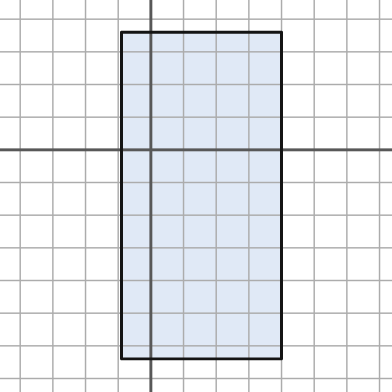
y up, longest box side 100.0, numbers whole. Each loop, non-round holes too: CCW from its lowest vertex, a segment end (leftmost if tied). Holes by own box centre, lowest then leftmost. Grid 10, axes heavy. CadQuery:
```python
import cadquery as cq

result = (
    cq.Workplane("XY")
    .moveTo(-9.0, -64.0)
    .lineTo(40.0, -64.0)
    .lineTo(40.0, 36.0)
    .lineTo(-9.0, 36.0)
    .close()
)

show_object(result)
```